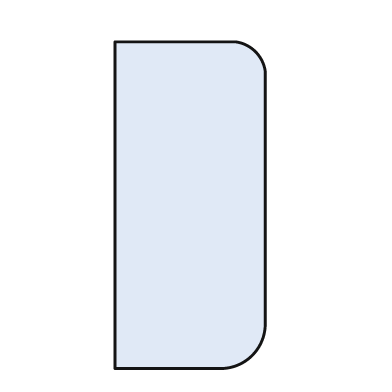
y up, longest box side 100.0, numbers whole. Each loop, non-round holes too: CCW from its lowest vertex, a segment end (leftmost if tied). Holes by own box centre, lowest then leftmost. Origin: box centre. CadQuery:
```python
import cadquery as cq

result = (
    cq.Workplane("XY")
    .moveTo(-23.0, -50.0)
    .lineTo(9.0, -50.0)
    .threePointArc((19.0, -46.0), (23.0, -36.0))
    .lineTo(23.0, 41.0)
    .threePointArc((20.0, 47.0), (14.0, 50.0))
    .lineTo(-23.0, 50.0)
    .close()
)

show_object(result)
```